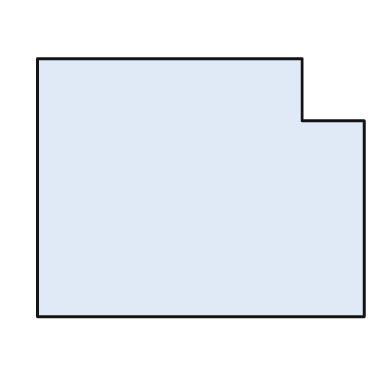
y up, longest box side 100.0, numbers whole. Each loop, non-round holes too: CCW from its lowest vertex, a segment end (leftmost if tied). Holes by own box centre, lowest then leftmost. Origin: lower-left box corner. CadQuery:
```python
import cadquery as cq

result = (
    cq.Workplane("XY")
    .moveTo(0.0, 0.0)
    .lineTo(100.0, 0.0)
    .lineTo(100.0, 60.0)
    .lineTo(81.0, 60.0)
    .lineTo(81.0, 79.0)
    .lineTo(0.0, 79.0)
    .close()
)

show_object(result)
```